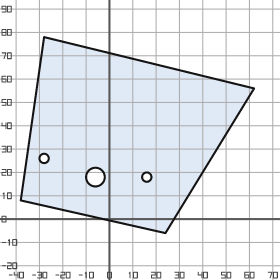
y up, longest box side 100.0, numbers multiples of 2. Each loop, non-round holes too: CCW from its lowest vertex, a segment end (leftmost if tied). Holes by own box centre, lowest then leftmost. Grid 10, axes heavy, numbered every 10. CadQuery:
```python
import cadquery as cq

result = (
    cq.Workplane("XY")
    .moveTo(24.0, -6.0)
    .lineTo(62.0, 56.0)
    .lineTo(-28.0, 78.0)
    .lineTo(-38.0, 8.0)
    .close()
    .moveTo(-6.0, 18.0)
    .circle(4.0)
    .moveTo(16.0, 18.0)
    .circle(2.0)
    .moveTo(-28.0, 26.0)
    .circle(2.0)
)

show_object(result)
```